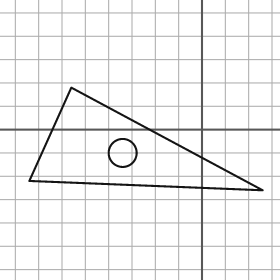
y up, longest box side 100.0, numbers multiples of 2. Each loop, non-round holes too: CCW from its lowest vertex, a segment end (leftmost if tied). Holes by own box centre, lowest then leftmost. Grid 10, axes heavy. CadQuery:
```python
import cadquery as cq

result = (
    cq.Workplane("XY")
    .moveTo(26.0, -26.0)
    .lineTo(-56.0, 18.0)
    .lineTo(-74.0, -22.0)
    .close()
    .moveTo(-34.0, -10.0)
    .circle(6.0)
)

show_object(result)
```